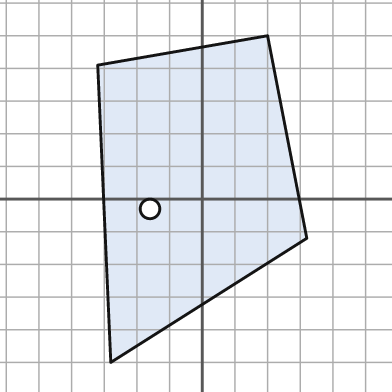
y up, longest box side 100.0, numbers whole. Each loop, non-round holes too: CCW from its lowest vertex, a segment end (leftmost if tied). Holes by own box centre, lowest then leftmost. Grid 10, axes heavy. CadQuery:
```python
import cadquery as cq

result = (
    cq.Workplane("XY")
    .moveTo(-28.0, -50.0)
    .lineTo(32.0, -12.0)
    .lineTo(20.0, 50.0)
    .lineTo(-32.0, 41.0)
    .close()
    .moveTo(-16.0, -3.0)
    .circle(3.0)
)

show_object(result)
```